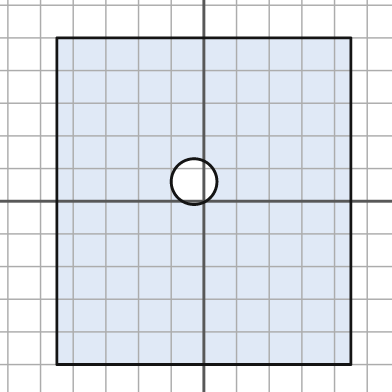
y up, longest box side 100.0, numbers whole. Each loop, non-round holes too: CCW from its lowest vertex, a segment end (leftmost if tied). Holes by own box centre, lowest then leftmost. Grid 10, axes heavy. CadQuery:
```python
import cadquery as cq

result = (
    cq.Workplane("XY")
    .moveTo(-45.0, -50.0)
    .lineTo(45.0, -50.0)
    .lineTo(45.0, 50.0)
    .lineTo(-45.0, 50.0)
    .close()
    .moveTo(-3.0, 6.0)
    .circle(7.0)
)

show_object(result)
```